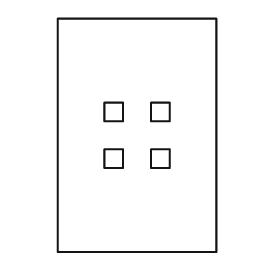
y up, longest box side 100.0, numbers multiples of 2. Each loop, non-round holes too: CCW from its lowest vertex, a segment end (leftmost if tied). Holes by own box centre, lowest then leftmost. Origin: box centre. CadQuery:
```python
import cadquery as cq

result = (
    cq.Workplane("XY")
    .moveTo(-34.0, -50.0)
    .lineTo(34.0, -50.0)
    .lineTo(34.0, 50.0)
    .lineTo(-34.0, 50.0)
    .close()
    .moveTo(-14.0, -14.0)
    .lineTo(-6.0, -14.0)
    .lineTo(-6.0, -6.0)
    .lineTo(-14.0, -6.0)
    .close()
    .moveTo(6.0, -14.0)
    .lineTo(14.0, -14.0)
    .lineTo(14.0, -6.0)
    .lineTo(6.0, -6.0)
    .close()
    .moveTo(-14.0, 6.0)
    .lineTo(-6.0, 6.0)
    .lineTo(-6.0, 14.0)
    .lineTo(-14.0, 14.0)
    .close()
    .moveTo(6.0, 6.0)
    .lineTo(14.0, 6.0)
    .lineTo(14.0, 14.0)
    .lineTo(6.0, 14.0)
    .close()
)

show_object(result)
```